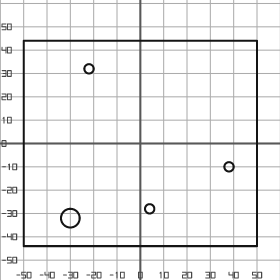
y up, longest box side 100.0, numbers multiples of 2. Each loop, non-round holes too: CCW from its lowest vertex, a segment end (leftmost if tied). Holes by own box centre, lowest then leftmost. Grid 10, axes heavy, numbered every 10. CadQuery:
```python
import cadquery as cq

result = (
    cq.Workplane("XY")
    .moveTo(-50.0, -44.0)
    .lineTo(50.0, -44.0)
    .lineTo(50.0, 44.0)
    .lineTo(-50.0, 44.0)
    .close()
    .moveTo(-30.0, -32.0)
    .circle(4.0)
    .moveTo(4.0, -28.0)
    .circle(2.0)
    .moveTo(38.0, -10.0)
    .circle(2.0)
    .moveTo(-22.0, 32.0)
    .circle(2.0)
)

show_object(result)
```